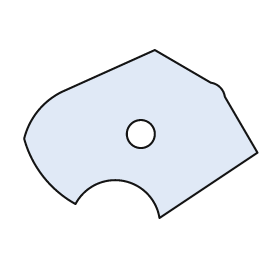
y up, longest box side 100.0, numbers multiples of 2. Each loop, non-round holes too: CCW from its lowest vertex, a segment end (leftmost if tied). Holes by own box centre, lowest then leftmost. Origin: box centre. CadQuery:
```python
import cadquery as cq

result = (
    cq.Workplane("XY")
    .moveTo(8.0, -36.0)
    .lineTo(50.0, -8.0)
    .lineTo(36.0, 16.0)
    .threePointArc((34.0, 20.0), (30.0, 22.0))
    .lineTo(6.0, 36.0)
    .lineTo(-34.0, 18.0)
    .threePointArc((-44.0, 10.0), (-50.0, -2.0))
    .threePointArc((-42.0, -18.0), (-28.0, -30.0))
    .threePointArc((-8.0, -20.0), (8.0, -36.0))
    .close()
    .moveTo(0.0, 0.0)
    .circle(6.0)
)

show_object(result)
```